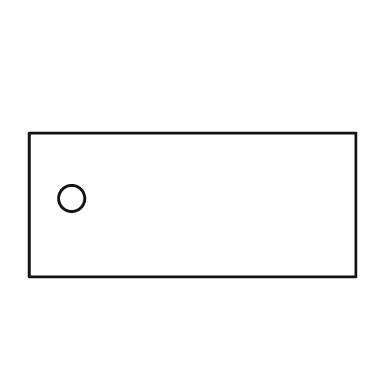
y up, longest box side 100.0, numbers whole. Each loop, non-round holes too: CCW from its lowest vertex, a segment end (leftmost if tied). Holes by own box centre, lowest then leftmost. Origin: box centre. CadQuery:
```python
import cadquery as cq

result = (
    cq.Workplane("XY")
    .moveTo(-50.0, -22.0)
    .lineTo(50.0, -22.0)
    .lineTo(50.0, 22.0)
    .lineTo(-50.0, 22.0)
    .close()
    .moveTo(-37.0, 2.0)
    .circle(4.0)
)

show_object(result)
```